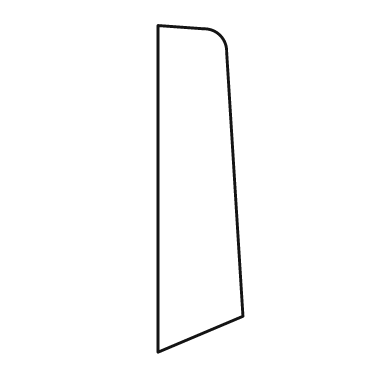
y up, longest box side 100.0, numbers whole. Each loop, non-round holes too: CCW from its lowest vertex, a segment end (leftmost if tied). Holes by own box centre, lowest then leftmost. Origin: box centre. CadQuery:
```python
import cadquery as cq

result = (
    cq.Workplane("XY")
    .moveTo(-13.0, -50.0)
    .lineTo(13.0, -39.0)
    .lineTo(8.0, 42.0)
    .threePointArc((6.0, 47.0), (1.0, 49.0))
    .lineTo(-13.0, 50.0)
    .close()
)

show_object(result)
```